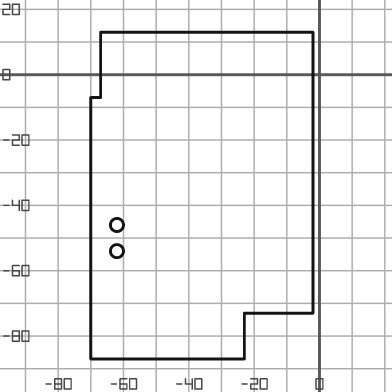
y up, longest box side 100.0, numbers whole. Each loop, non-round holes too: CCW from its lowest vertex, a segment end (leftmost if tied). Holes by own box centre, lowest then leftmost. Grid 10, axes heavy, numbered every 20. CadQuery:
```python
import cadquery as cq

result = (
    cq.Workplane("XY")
    .moveTo(-70.0, -87.0)
    .lineTo(-23.0, -87.0)
    .lineTo(-23.0, -73.0)
    .lineTo(-2.0, -73.0)
    .lineTo(-2.0, 13.0)
    .lineTo(-67.0, 13.0)
    .lineTo(-67.0, -7.0)
    .lineTo(-70.0, -7.0)
    .close()
    .moveTo(-62.0, -54.0)
    .circle(2.0)
    .moveTo(-62.0, -46.0)
    .circle(2.0)
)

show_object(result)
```